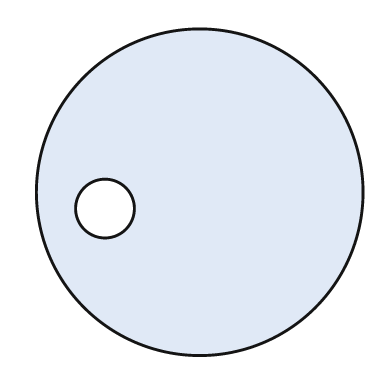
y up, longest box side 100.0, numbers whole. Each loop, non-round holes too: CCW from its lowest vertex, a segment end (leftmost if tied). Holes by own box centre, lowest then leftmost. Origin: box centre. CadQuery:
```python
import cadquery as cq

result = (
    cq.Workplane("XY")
    .moveTo(0.0, 0.0)
    .circle(50.0)
    .moveTo(-29.0, -5.0)
    .circle(9.0)
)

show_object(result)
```